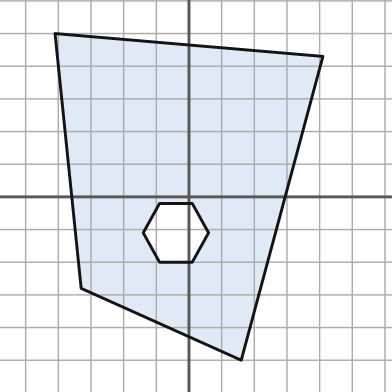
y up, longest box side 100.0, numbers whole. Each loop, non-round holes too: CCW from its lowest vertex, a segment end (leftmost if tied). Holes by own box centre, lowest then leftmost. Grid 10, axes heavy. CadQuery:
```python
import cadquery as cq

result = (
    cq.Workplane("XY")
    .moveTo(16.0, -50.0)
    .lineTo(41.0, 43.0)
    .lineTo(-41.0, 50.0)
    .lineTo(-33.0, -28.0)
    .close()
    .moveTo(-9.0, -20.0)
    .lineTo(1.0, -20.0)
    .lineTo(6.0, -11.0)
    .lineTo(1.0, -2.0)
    .lineTo(-9.0, -2.0)
    .lineTo(-14.0, -11.0)
    .close()
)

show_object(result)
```